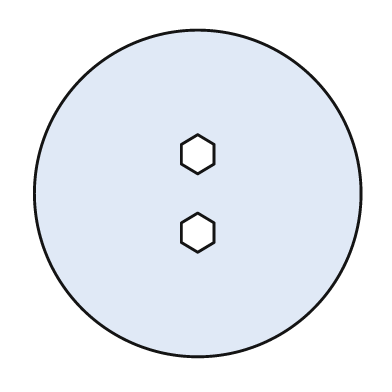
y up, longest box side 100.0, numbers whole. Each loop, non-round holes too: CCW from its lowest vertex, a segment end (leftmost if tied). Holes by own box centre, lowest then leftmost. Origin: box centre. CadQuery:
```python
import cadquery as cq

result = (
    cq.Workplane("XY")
    .moveTo(0.0, 0.0)
    .circle(50.0)
    .moveTo(0.0, -18.0)
    .lineTo(5.0, -15.0)
    .lineTo(5.0, -9.0)
    .lineTo(0.0, -6.0)
    .lineTo(-5.0, -9.0)
    .lineTo(-5.0, -15.0)
    .close()
    .moveTo(0.0, 6.0)
    .lineTo(5.0, 9.0)
    .lineTo(5.0, 15.0)
    .lineTo(0.0, 18.0)
    .lineTo(-5.0, 15.0)
    .lineTo(-5.0, 9.0)
    .close()
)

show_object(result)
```